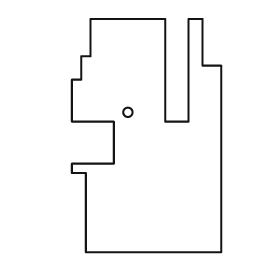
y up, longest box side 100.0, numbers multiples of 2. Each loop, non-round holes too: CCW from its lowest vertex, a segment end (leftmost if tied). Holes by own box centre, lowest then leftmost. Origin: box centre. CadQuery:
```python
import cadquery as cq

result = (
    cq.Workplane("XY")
    .moveTo(-26.0, -50.0)
    .lineTo(32.0, -50.0)
    .lineTo(32.0, 30.0)
    .lineTo(24.0, 30.0)
    .lineTo(24.0, 50.0)
    .lineTo(18.0, 50.0)
    .lineTo(18.0, 6.0)
    .lineTo(8.0, 6.0)
    .lineTo(8.0, 50.0)
    .lineTo(-24.0, 50.0)
    .lineTo(-24.0, 34.0)
    .lineTo(-28.0, 34.0)
    .lineTo(-28.0, 24.0)
    .lineTo(-32.0, 24.0)
    .lineTo(-32.0, 6.0)
    .lineTo(-14.0, 6.0)
    .lineTo(-14.0, -12.0)
    .lineTo(-32.0, -12.0)
    .lineTo(-32.0, -16.0)
    .lineTo(-26.0, -16.0)
    .close()
    .moveTo(-8.0, 10.0)
    .circle(2.0)
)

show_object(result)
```